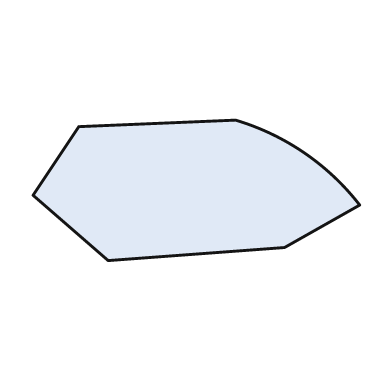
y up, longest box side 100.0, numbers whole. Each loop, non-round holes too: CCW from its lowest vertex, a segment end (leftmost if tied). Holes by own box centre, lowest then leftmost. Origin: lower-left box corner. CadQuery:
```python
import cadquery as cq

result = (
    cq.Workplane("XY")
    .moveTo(23.0, 0.0)
    .lineTo(77.0, 4.0)
    .lineTo(100.0, 17.0)
    .threePointArc((83.0, 33.0), (62.0, 43.0))
    .lineTo(14.0, 41.0)
    .lineTo(0.0, 20.0)
    .close()
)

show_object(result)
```